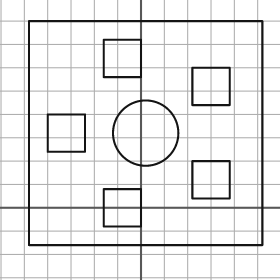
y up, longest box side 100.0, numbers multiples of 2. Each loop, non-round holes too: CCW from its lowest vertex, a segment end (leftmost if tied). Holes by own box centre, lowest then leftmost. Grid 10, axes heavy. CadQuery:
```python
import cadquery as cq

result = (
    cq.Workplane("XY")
    .moveTo(-48.0, -16.0)
    .lineTo(52.0, -16.0)
    .lineTo(52.0, 80.0)
    .lineTo(-48.0, 80.0)
    .close()
    .moveTo(-16.0, -8.0)
    .lineTo(0.0, -8.0)
    .lineTo(0.0, 8.0)
    .lineTo(-16.0, 8.0)
    .close()
    .moveTo(22.0, 4.0)
    .lineTo(38.0, 4.0)
    .lineTo(38.0, 20.0)
    .lineTo(22.0, 20.0)
    .close()
    .moveTo(-40.0, 24.0)
    .lineTo(-24.0, 24.0)
    .lineTo(-24.0, 40.0)
    .lineTo(-40.0, 40.0)
    .close()
    .moveTo(2.0, 32.0)
    .circle(14.0)
    .moveTo(22.0, 44.0)
    .lineTo(38.0, 44.0)
    .lineTo(38.0, 60.0)
    .lineTo(22.0, 60.0)
    .close()
    .moveTo(-16.0, 56.0)
    .lineTo(0.0, 56.0)
    .lineTo(0.0, 72.0)
    .lineTo(-16.0, 72.0)
    .close()
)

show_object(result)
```